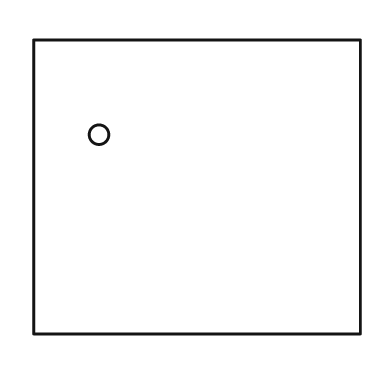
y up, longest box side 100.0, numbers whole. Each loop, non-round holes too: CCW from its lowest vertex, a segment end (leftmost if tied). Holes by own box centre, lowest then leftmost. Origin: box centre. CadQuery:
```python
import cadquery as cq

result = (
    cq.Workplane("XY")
    .moveTo(-50.0, -45.0)
    .lineTo(50.0, -45.0)
    .lineTo(50.0, 45.0)
    .lineTo(-50.0, 45.0)
    .close()
    .moveTo(-30.0, 16.0)
    .circle(3.0)
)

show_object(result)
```